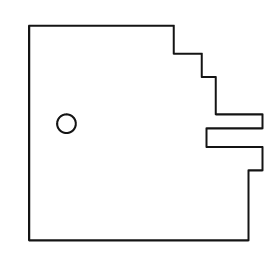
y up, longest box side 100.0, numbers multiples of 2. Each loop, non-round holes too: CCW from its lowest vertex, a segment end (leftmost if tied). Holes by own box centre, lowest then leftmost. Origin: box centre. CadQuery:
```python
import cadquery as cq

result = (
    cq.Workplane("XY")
    .moveTo(-50.0, -46.0)
    .lineTo(44.0, -46.0)
    .lineTo(44.0, -16.0)
    .lineTo(50.0, -16.0)
    .lineTo(50.0, -6.0)
    .lineTo(26.0, -6.0)
    .lineTo(26.0, 2.0)
    .lineTo(50.0, 2.0)
    .lineTo(50.0, 8.0)
    .lineTo(30.0, 8.0)
    .lineTo(30.0, 24.0)
    .lineTo(24.0, 24.0)
    .lineTo(24.0, 34.0)
    .lineTo(12.0, 34.0)
    .lineTo(12.0, 46.0)
    .lineTo(-50.0, 46.0)
    .close()
    .moveTo(-34.0, 4.0)
    .circle(4.0)
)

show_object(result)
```